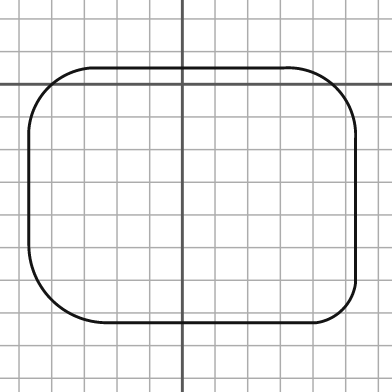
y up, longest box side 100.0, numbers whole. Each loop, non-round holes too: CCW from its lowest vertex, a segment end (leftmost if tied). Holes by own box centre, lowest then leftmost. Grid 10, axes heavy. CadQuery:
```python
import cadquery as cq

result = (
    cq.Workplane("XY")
    .moveTo(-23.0, -73.0)
    .lineTo(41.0, -73.0)
    .threePointArc((49.0, -69.0), (53.0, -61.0))
    .lineTo(53.0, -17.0)
    .threePointArc((47.0, -1.0), (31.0, 5.0))
    .lineTo(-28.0, 5.0)
    .threePointArc((-41.0, -1.0), (-47.0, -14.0))
    .lineTo(-47.0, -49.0)
    .threePointArc((-40.0, -66.0), (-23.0, -73.0))
    .close()
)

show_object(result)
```